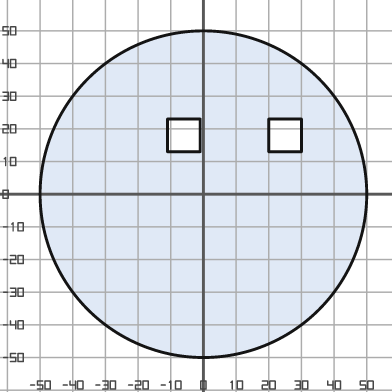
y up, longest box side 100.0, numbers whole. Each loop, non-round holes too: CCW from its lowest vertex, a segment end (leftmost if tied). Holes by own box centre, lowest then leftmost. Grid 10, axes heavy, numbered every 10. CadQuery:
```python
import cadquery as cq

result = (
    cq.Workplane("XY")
    .moveTo(0.0, 0.0)
    .circle(50.0)
    .moveTo(-11.0, 13.0)
    .lineTo(-1.0, 13.0)
    .lineTo(-1.0, 23.0)
    .lineTo(-11.0, 23.0)
    .close()
    .moveTo(20.0, 13.0)
    .lineTo(30.0, 13.0)
    .lineTo(30.0, 23.0)
    .lineTo(20.0, 23.0)
    .close()
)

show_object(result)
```